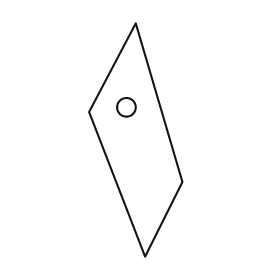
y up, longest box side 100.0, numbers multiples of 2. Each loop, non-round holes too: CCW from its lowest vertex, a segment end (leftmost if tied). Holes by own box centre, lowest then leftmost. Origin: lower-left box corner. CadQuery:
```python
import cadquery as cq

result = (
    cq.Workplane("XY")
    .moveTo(24.0, 0.0)
    .lineTo(40.0, 32.0)
    .lineTo(20.0, 100.0)
    .lineTo(0.0, 62.0)
    .close()
    .moveTo(16.0, 64.0)
    .circle(4.0)
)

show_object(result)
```